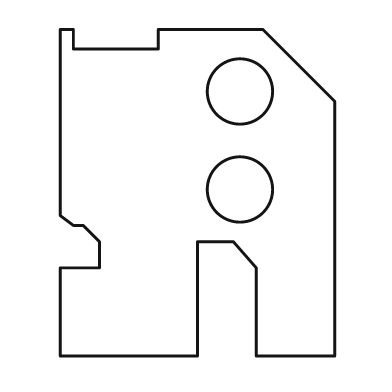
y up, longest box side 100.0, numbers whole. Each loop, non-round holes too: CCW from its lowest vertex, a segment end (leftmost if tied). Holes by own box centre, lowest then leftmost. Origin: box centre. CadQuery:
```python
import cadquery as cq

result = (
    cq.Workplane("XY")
    .moveTo(-42.0, -50.0)
    .lineTo(0.0, -50.0)
    .lineTo(0.0, -15.0)
    .lineTo(11.0, -15.0)
    .lineTo(18.0, -23.0)
    .lineTo(18.0, -50.0)
    .lineTo(42.0, -50.0)
    .lineTo(42.0, 28.0)
    .lineTo(20.0, 50.0)
    .lineTo(-12.0, 50.0)
    .lineTo(-12.0, 44.0)
    .lineTo(-38.0, 44.0)
    .lineTo(-38.0, 50.0)
    .lineTo(-42.0, 50.0)
    .lineTo(-42.0, -7.0)
    .lineTo(-38.0, -10.0)
    .lineTo(-35.0, -10.0)
    .lineTo(-30.0, -15.0)
    .lineTo(-30.0, -23.0)
    .lineTo(-42.0, -23.0)
    .close()
    .moveTo(13.0, 1.0)
    .circle(10.0)
    .moveTo(13.0, 31.0)
    .circle(10.0)
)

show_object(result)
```